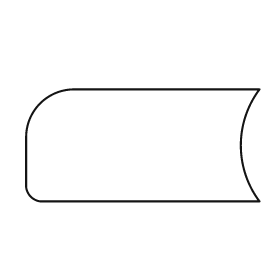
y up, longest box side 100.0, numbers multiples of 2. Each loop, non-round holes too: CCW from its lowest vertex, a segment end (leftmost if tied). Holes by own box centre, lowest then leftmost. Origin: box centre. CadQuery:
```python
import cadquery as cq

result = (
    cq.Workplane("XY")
    .moveTo(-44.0, -24.0)
    .lineTo(50.0, -24.0)
    .threePointArc((42.0, 0.0), (50.0, 24.0))
    .lineTo(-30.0, 24.0)
    .threePointArc((-44.0, 18.0), (-50.0, 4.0))
    .lineTo(-50.0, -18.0)
    .threePointArc((-48.0, -22.0), (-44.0, -24.0))
    .close()
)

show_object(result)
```